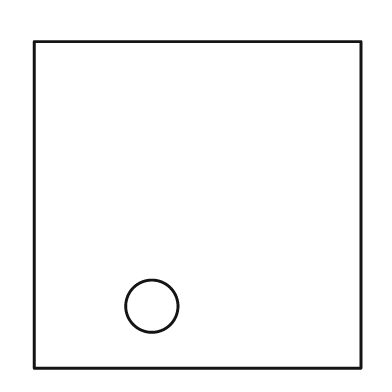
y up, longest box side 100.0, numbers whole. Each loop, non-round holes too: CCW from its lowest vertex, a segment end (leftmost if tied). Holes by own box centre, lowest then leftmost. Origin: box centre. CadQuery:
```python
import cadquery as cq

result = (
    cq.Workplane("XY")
    .moveTo(-50.0, -50.0)
    .lineTo(50.0, -50.0)
    .lineTo(50.0, 50.0)
    .lineTo(-50.0, 50.0)
    .close()
    .moveTo(-14.0, -31.0)
    .circle(8.0)
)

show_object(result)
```